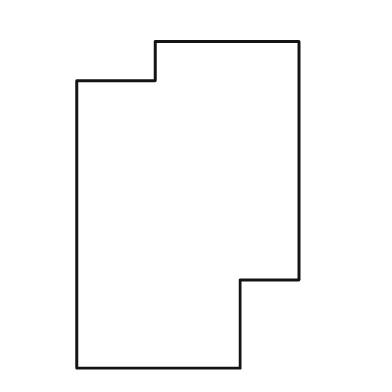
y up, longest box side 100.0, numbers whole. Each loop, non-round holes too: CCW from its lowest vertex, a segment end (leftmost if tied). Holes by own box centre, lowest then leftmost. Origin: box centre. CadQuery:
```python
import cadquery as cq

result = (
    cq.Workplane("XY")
    .moveTo(-34.0, -50.0)
    .lineTo(16.0, -50.0)
    .lineTo(16.0, -23.0)
    .lineTo(34.0, -23.0)
    .lineTo(34.0, 50.0)
    .lineTo(-10.0, 50.0)
    .lineTo(-10.0, 38.0)
    .lineTo(-34.0, 38.0)
    .close()
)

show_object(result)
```